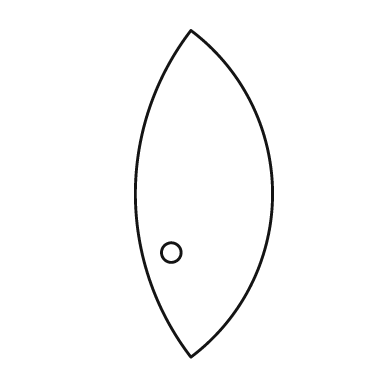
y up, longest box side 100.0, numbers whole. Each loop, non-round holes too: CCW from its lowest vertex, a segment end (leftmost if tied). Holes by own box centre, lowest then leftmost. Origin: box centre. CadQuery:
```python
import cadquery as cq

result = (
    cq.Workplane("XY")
    .moveTo(-4.0, -50.0)
    .threePointArc((21.0, 0.0), (-4.0, 50.0))
    .threePointArc((-21.0, 0.0), (-4.0, -50.0))
    .close()
    .moveTo(-10.0, -18.0)
    .circle(3.0)
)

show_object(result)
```